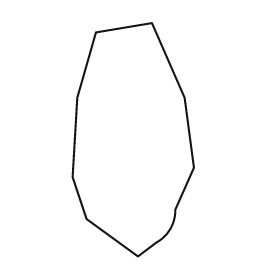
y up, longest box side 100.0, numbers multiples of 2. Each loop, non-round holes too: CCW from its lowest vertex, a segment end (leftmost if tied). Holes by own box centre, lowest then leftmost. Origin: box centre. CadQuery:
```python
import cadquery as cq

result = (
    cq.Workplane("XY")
    .moveTo(2.0, -50.0)
    .lineTo(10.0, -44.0)
    .threePointArc((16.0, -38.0), (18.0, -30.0))
    .lineTo(26.0, -12.0)
    .lineTo(22.0, 18.0)
    .lineTo(8.0, 50.0)
    .lineTo(-16.0, 46.0)
    .lineTo(-24.0, 18.0)
    .lineTo(-26.0, -16.0)
    .lineTo(-20.0, -34.0)
    .close()
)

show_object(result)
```